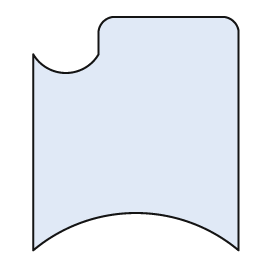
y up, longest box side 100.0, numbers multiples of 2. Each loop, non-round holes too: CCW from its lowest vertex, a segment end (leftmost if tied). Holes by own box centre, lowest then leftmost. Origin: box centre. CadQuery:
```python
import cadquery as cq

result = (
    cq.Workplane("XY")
    .moveTo(-44.0, -50.0)
    .threePointArc((0.0, -34.0), (44.0, -50.0))
    .lineTo(44.0, 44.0)
    .threePointArc((42.0, 48.0), (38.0, 50.0))
    .lineTo(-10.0, 50.0)
    .threePointArc((-14.0, 48.0), (-16.0, 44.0))
    .lineTo(-16.0, 34.0)
    .threePointArc((-30.0, 26.0), (-44.0, 34.0))
    .close()
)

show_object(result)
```